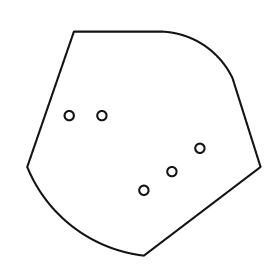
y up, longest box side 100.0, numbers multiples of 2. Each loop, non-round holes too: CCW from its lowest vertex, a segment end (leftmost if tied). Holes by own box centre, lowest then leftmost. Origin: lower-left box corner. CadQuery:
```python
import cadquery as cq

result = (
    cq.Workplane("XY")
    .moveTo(50.0, 0.0)
    .lineTo(100.0, 38.0)
    .lineTo(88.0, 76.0)
    .threePointArc((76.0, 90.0), (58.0, 96.0))
    .lineTo(20.0, 96.0)
    .lineTo(0.0, 38.0)
    .threePointArc((20.0, 12.0), (50.0, 0.0))
    .close()
    .moveTo(50.0, 28.0)
    .circle(2.0)
    .moveTo(62.0, 36.0)
    .circle(2.0)
    .moveTo(74.0, 46.0)
    .circle(2.0)
    .moveTo(18.0, 60.0)
    .circle(2.0)
    .moveTo(32.0, 60.0)
    .circle(2.0)
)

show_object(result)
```